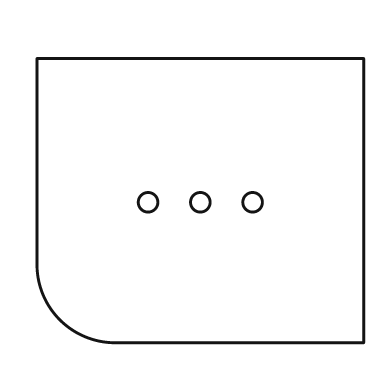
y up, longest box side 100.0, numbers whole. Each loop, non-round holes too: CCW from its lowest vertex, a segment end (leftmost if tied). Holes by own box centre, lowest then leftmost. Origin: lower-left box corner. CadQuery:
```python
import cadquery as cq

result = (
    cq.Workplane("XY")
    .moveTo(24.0, 0.0)
    .lineTo(100.0, 0.0)
    .lineTo(100.0, 87.0)
    .lineTo(0.0, 87.0)
    .lineTo(0.0, 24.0)
    .threePointArc((7.0, 7.0), (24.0, 0.0))
    .close()
    .moveTo(34.0, 43.0)
    .circle(3.0)
    .moveTo(50.0, 43.0)
    .circle(3.0)
    .moveTo(66.0, 43.0)
    .circle(3.0)
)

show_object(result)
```